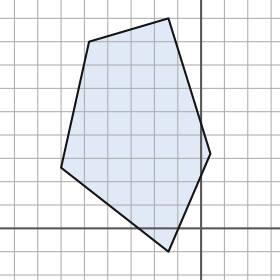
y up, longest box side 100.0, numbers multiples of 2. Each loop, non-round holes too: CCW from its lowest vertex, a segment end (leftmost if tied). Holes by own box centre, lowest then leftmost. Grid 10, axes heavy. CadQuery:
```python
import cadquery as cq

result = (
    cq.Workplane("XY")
    .moveTo(-14.0, -10.0)
    .lineTo(4.0, 32.0)
    .lineTo(-14.0, 90.0)
    .lineTo(-48.0, 80.0)
    .lineTo(-60.0, 26.0)
    .close()
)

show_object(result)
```